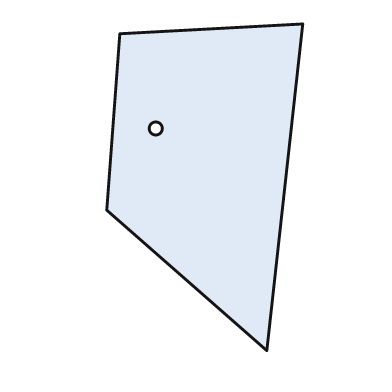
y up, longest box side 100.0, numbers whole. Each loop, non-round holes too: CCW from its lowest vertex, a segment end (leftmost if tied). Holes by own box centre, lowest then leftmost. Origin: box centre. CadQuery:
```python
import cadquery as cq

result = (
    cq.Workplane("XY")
    .moveTo(19.0, -50.0)
    .lineTo(30.0, 50.0)
    .lineTo(-26.0, 47.0)
    .lineTo(-30.0, -7.0)
    .close()
    .moveTo(-15.0, 18.0)
    .circle(2.0)
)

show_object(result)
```